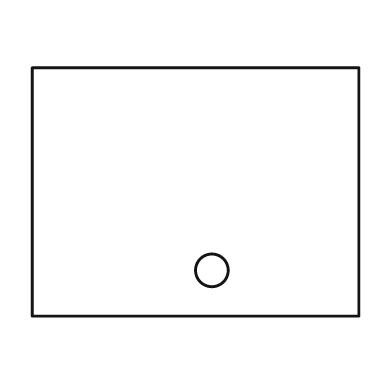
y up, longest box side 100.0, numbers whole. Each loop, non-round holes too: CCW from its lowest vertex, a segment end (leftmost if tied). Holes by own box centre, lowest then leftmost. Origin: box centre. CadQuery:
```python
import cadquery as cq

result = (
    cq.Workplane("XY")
    .moveTo(-50.0, -38.0)
    .lineTo(50.0, -38.0)
    .lineTo(50.0, 38.0)
    .lineTo(-50.0, 38.0)
    .close()
    .moveTo(5.0, -24.0)
    .circle(5.0)
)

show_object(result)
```